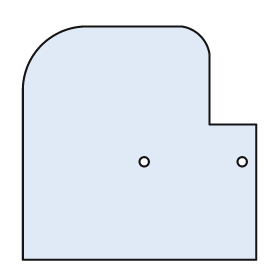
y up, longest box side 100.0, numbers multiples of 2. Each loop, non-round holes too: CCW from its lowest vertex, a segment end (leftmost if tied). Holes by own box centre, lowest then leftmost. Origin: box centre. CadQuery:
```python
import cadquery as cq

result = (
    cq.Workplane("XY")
    .moveTo(-50.0, -50.0)
    .lineTo(50.0, -50.0)
    .lineTo(50.0, 8.0)
    .lineTo(30.0, 8.0)
    .lineTo(30.0, 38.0)
    .threePointArc((26.0, 46.0), (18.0, 50.0))
    .lineTo(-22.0, 50.0)
    .threePointArc((-42.0, 42.0), (-50.0, 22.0))
    .close()
    .moveTo(2.0, -8.0)
    .circle(2.0)
    .moveTo(44.0, -8.0)
    .circle(2.0)
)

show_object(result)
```